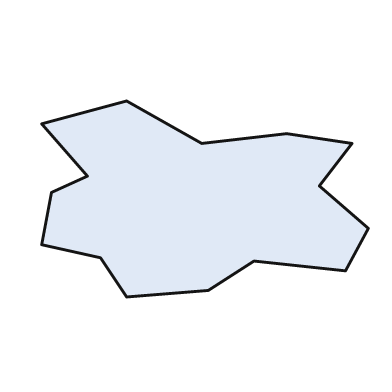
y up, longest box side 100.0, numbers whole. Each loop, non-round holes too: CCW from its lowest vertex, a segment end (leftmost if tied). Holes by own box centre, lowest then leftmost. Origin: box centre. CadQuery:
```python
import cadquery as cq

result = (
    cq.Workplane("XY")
    .moveTo(-24.0, -30.0)
    .lineTo(1.0, -28.0)
    .lineTo(15.0, -19.0)
    .lineTo(43.0, -22.0)
    .lineTo(50.0, -9.0)
    .lineTo(35.0, 4.0)
    .lineTo(45.0, 17.0)
    .lineTo(25.0, 20.0)
    .lineTo(-1.0, 17.0)
    .lineTo(-24.0, 30.0)
    .lineTo(-50.0, 23.0)
    .lineTo(-36.0, 7.0)
    .lineTo(-47.0, 2.0)
    .lineTo(-50.0, -14.0)
    .lineTo(-32.0, -18.0)
    .close()
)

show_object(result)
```